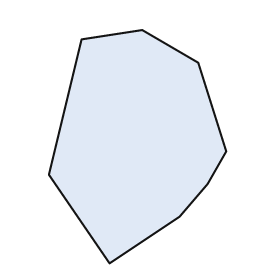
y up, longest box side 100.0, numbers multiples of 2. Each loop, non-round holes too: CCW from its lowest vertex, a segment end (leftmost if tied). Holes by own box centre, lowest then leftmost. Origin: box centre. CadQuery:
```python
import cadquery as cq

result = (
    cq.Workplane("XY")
    .moveTo(-12.0, -50.0)
    .lineTo(18.0, -30.0)
    .lineTo(30.0, -16.0)
    .lineTo(38.0, -2.0)
    .lineTo(26.0, 36.0)
    .lineTo(2.0, 50.0)
    .lineTo(-24.0, 46.0)
    .lineTo(-38.0, -12.0)
    .close()
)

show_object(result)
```